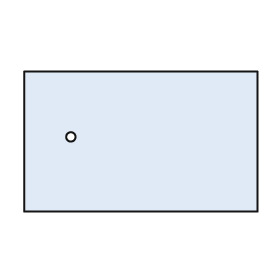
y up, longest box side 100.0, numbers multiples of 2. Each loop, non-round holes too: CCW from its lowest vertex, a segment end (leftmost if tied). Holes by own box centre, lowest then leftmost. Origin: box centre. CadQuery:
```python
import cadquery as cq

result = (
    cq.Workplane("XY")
    .moveTo(-50.0, -30.0)
    .lineTo(50.0, -30.0)
    .lineTo(50.0, 30.0)
    .lineTo(-50.0, 30.0)
    .close()
    .moveTo(-30.0, 2.0)
    .circle(2.0)
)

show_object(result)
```